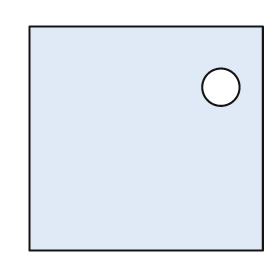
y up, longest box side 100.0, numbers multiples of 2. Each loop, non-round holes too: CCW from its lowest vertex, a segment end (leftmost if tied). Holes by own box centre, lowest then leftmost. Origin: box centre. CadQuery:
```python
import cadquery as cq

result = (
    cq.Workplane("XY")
    .moveTo(-50.0, -48.0)
    .lineTo(50.0, -48.0)
    .lineTo(50.0, 48.0)
    .lineTo(-50.0, 48.0)
    .close()
    .moveTo(32.0, 22.0)
    .circle(8.0)
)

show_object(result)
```